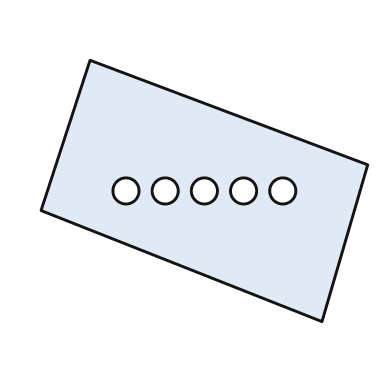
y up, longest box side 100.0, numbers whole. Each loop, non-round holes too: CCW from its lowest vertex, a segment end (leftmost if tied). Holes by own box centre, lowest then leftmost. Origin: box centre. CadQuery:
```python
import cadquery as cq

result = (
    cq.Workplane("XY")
    .moveTo(36.0, -40.0)
    .lineTo(50.0, 8.0)
    .lineTo(-35.0, 40.0)
    .lineTo(-50.0, -6.0)
    .close()
    .moveTo(-24.0, 0.0)
    .circle(4.0)
    .moveTo(-12.0, 0.0)
    .circle(4.0)
    .moveTo(0.0, 0.0)
    .circle(4.0)
    .moveTo(12.0, 0.0)
    .circle(4.0)
    .moveTo(24.0, 0.0)
    .circle(4.0)
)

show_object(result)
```